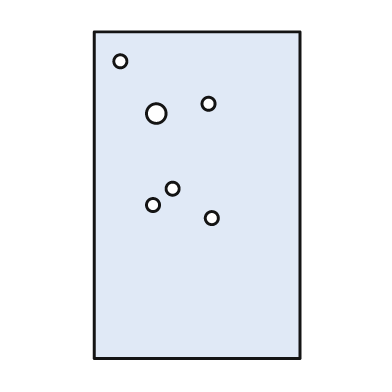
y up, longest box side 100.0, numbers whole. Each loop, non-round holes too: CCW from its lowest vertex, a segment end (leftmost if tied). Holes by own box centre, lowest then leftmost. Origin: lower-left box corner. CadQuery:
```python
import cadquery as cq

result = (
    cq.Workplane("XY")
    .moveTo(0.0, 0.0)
    .lineTo(63.0, 0.0)
    .lineTo(63.0, 100.0)
    .lineTo(0.0, 100.0)
    .close()
    .moveTo(36.0, 43.0)
    .circle(2.0)
    .moveTo(18.0, 47.0)
    .circle(2.0)
    .moveTo(24.0, 52.0)
    .circle(2.0)
    .moveTo(19.0, 75.0)
    .circle(3.0)
    .moveTo(35.0, 78.0)
    .circle(2.0)
    .moveTo(8.0, 91.0)
    .circle(2.0)
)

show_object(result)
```